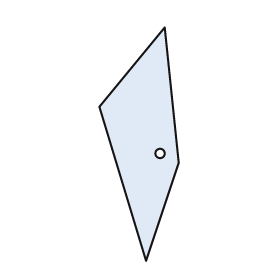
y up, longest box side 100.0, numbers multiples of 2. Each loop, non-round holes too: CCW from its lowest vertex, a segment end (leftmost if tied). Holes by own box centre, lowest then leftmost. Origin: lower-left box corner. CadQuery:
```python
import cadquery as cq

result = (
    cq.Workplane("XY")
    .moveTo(20.0, 0.0)
    .lineTo(34.0, 42.0)
    .lineTo(28.0, 100.0)
    .lineTo(0.0, 66.0)
    .close()
    .moveTo(26.0, 46.0)
    .circle(2.0)
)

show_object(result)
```